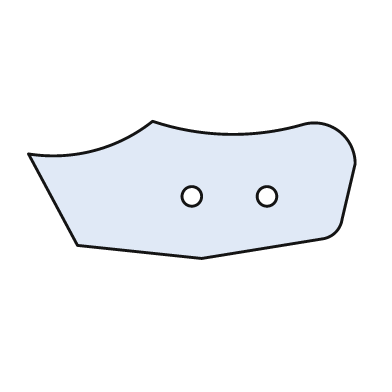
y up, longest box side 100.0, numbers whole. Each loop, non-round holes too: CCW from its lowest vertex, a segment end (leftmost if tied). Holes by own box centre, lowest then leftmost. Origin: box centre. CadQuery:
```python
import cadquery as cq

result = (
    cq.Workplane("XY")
    .moveTo(3.0, -21.0)
    .lineTo(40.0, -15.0)
    .threePointArc((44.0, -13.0), (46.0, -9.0))
    .lineTo(50.0, 8.0)
    .threePointArc((45.0, 18.0), (34.0, 20.0))
    .threePointArc((11.0, 17.0), (-12.0, 21.0))
    .threePointArc((-30.0, 12.0), (-50.0, 11.0))
    .lineTo(-35.0, -17.0)
    .close()
    .moveTo(0.0, -2.0)
    .circle(3.0)
    .moveTo(23.0, -2.0)
    .circle(3.0)
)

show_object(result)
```